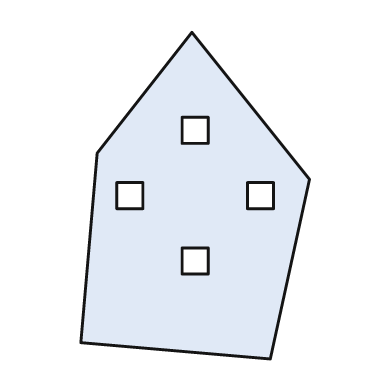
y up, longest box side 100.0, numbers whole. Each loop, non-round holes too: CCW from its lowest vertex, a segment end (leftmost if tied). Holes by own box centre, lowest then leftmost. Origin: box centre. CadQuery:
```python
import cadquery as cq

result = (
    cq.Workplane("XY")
    .moveTo(23.0, -50.0)
    .lineTo(35.0, 5.0)
    .lineTo(-1.0, 50.0)
    .lineTo(-30.0, 13.0)
    .lineTo(-35.0, -45.0)
    .close()
    .moveTo(-4.0, -24.0)
    .lineTo(4.0, -24.0)
    .lineTo(4.0, -16.0)
    .lineTo(-4.0, -16.0)
    .close()
    .moveTo(-24.0, -4.0)
    .lineTo(-16.0, -4.0)
    .lineTo(-16.0, 4.0)
    .lineTo(-24.0, 4.0)
    .close()
    .moveTo(16.0, -4.0)
    .lineTo(24.0, -4.0)
    .lineTo(24.0, 4.0)
    .lineTo(16.0, 4.0)
    .close()
    .moveTo(-4.0, 16.0)
    .lineTo(4.0, 16.0)
    .lineTo(4.0, 24.0)
    .lineTo(-4.0, 24.0)
    .close()
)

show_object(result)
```